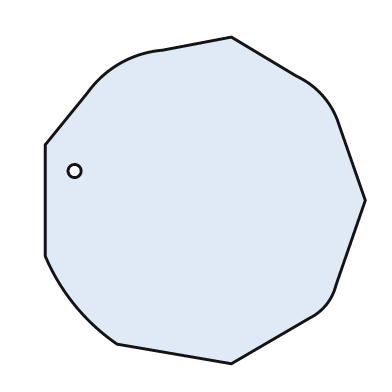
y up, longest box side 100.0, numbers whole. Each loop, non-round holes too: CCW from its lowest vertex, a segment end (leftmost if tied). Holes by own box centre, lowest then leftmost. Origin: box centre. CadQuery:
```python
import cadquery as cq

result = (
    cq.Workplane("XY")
    .moveTo(8.0, -50.0)
    .lineTo(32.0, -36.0)
    .threePointArc((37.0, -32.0), (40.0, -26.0))
    .lineTo(49.0, 0.0)
    .lineTo(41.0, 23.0)
    .threePointArc((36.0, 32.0), (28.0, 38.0))
    .lineTo(8.0, 50.0)
    .lineTo(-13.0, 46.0)
    .threePointArc((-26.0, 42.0), (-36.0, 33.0))
    .lineTo(-49.0, 17.0)
    .lineTo(-49.0, -17.0)
    .threePointArc((-40.0, -32.0), (-27.0, -44.0))
    .close()
    .moveTo(-40.0, 9.0)
    .circle(2.0)
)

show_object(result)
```